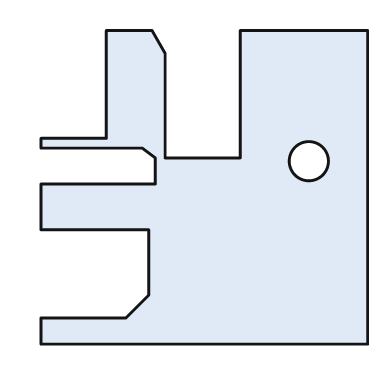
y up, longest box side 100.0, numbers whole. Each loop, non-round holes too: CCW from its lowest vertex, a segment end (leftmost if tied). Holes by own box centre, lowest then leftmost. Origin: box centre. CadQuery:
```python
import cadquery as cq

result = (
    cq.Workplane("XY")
    .moveTo(-50.0, -48.0)
    .lineTo(50.0, -48.0)
    .lineTo(50.0, 48.0)
    .lineTo(11.0, 48.0)
    .lineTo(11.0, 9.0)
    .lineTo(-12.0, 9.0)
    .lineTo(-12.0, 41.0)
    .lineTo(-16.0, 48.0)
    .lineTo(-30.0, 48.0)
    .lineTo(-30.0, 15.0)
    .lineTo(-50.0, 15.0)
    .lineTo(-50.0, 12.0)
    .lineTo(-19.0, 12.0)
    .lineTo(-15.0, 9.0)
    .lineTo(-15.0, 1.0)
    .lineTo(-50.0, 1.0)
    .lineTo(-50.0, -13.0)
    .lineTo(-17.0, -13.0)
    .lineTo(-17.0, -33.0)
    .lineTo(-24.0, -40.0)
    .lineTo(-50.0, -40.0)
    .close()
    .moveTo(32.0, 8.0)
    .circle(6.0)
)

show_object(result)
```